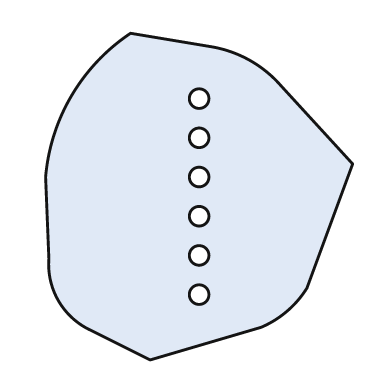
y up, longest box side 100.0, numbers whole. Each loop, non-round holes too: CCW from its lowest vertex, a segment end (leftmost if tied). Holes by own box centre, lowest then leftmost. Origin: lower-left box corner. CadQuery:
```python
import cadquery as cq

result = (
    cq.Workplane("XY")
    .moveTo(32.0, 0.0)
    .lineTo(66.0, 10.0)
    .threePointArc((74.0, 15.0), (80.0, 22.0))
    .lineTo(94.0, 60.0)
    .lineTo(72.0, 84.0)
    .threePointArc((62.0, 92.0), (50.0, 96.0))
    .lineTo(26.0, 100.0)
    .threePointArc((8.0, 81.0), (0.0, 56.0))
    .lineTo(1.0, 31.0)
    .threePointArc((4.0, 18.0), (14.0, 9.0))
    .close()
    .moveTo(47.0, 20.0)
    .circle(3.0)
    .moveTo(47.0, 32.0)
    .circle(3.0)
    .moveTo(47.0, 44.0)
    .circle(3.0)
    .moveTo(47.0, 56.0)
    .circle(3.0)
    .moveTo(47.0, 68.0)
    .circle(3.0)
    .moveTo(47.0, 80.0)
    .circle(3.0)
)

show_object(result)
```